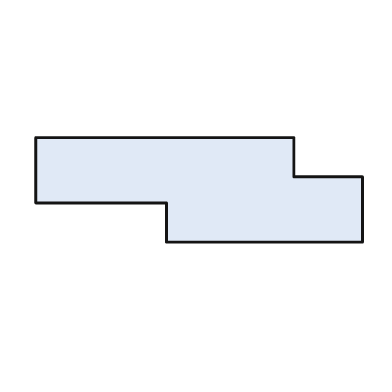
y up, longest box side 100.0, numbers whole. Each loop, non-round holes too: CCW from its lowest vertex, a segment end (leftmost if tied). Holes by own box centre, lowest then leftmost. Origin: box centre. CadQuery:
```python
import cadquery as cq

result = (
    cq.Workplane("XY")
    .moveTo(-10.0, -16.0)
    .lineTo(50.0, -16.0)
    .lineTo(50.0, 4.0)
    .lineTo(29.0, 4.0)
    .lineTo(29.0, 16.0)
    .lineTo(-50.0, 16.0)
    .lineTo(-50.0, -4.0)
    .lineTo(-10.0, -4.0)
    .close()
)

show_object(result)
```